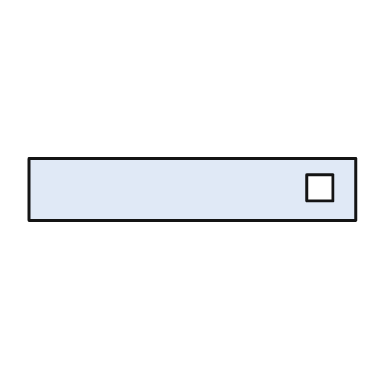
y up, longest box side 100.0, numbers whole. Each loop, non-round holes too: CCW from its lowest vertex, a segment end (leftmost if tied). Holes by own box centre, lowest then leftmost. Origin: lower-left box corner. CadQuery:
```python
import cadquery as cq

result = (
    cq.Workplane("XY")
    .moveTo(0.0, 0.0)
    .lineTo(100.0, 0.0)
    .lineTo(100.0, 19.0)
    .lineTo(0.0, 19.0)
    .close()
    .moveTo(85.0, 6.0)
    .lineTo(93.0, 6.0)
    .lineTo(93.0, 14.0)
    .lineTo(85.0, 14.0)
    .close()
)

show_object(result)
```